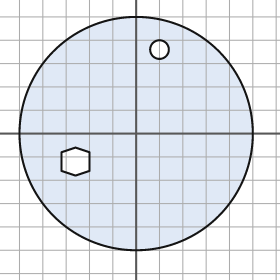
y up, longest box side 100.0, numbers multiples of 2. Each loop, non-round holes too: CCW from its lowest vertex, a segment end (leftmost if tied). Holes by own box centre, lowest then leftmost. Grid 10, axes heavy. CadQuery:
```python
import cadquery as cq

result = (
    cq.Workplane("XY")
    .moveTo(0.0, 0.0)
    .circle(50.0)
    .moveTo(-26.0, -18.0)
    .lineTo(-20.0, -16.0)
    .lineTo(-20.0, -8.0)
    .lineTo(-26.0, -6.0)
    .lineTo(-32.0, -8.0)
    .lineTo(-32.0, -16.0)
    .close()
    .moveTo(10.0, 36.0)
    .circle(4.0)
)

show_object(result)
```